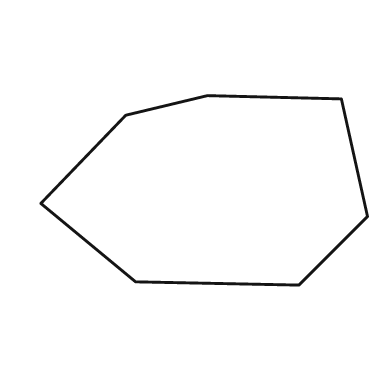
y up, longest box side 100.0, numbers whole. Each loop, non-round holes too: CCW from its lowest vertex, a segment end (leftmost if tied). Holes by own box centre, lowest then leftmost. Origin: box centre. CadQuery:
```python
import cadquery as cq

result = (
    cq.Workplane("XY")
    .moveTo(29.0, -29.0)
    .lineTo(50.0, -8.0)
    .lineTo(42.0, 28.0)
    .lineTo(1.0, 29.0)
    .lineTo(-24.0, 23.0)
    .lineTo(-50.0, -4.0)
    .lineTo(-21.0, -28.0)
    .close()
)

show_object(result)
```